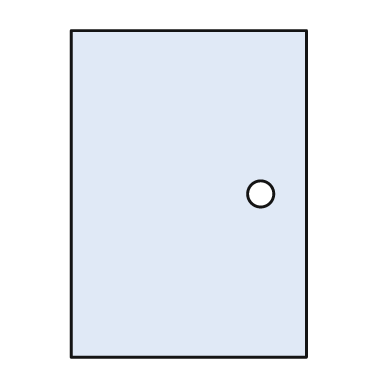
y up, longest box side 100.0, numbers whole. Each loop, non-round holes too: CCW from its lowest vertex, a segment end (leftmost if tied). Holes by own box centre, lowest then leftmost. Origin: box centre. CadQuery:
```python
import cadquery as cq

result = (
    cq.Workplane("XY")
    .moveTo(-36.0, -50.0)
    .lineTo(36.0, -50.0)
    .lineTo(36.0, 50.0)
    .lineTo(-36.0, 50.0)
    .close()
    .moveTo(22.0, 0.0)
    .circle(4.0)
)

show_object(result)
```